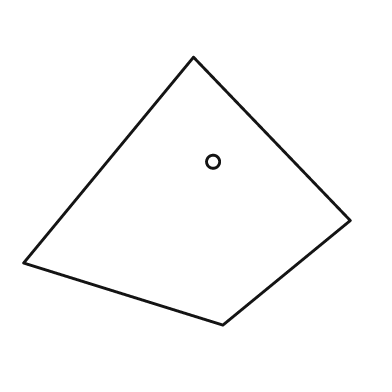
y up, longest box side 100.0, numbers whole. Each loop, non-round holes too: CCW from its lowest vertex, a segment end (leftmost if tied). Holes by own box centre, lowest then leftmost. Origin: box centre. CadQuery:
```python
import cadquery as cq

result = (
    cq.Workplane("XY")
    .moveTo(11.0, -41.0)
    .lineTo(50.0, -9.0)
    .lineTo(2.0, 41.0)
    .lineTo(-50.0, -22.0)
    .close()
    .moveTo(8.0, 9.0)
    .circle(2.0)
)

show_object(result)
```